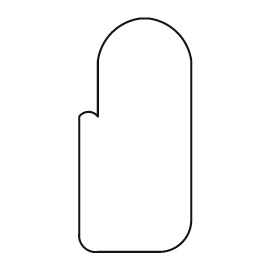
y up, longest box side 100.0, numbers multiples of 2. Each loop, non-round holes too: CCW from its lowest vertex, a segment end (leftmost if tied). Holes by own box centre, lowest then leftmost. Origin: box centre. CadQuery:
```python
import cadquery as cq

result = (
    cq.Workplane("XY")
    .moveTo(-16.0, -50.0)
    .lineTo(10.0, -50.0)
    .threePointArc((20.0, -46.0), (24.0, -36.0))
    .lineTo(24.0, 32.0)
    .threePointArc((18.0, 44.0), (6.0, 50.0))
    .lineTo(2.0, 50.0)
    .threePointArc((-10.0, 44.0), (-16.0, 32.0))
    .lineTo(-16.0, 8.0)
    .threePointArc((-20.0, 10.0), (-24.0, 8.0))
    .lineTo(-24.0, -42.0)
    .threePointArc((-22.0, -48.0), (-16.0, -50.0))
    .close()
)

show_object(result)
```